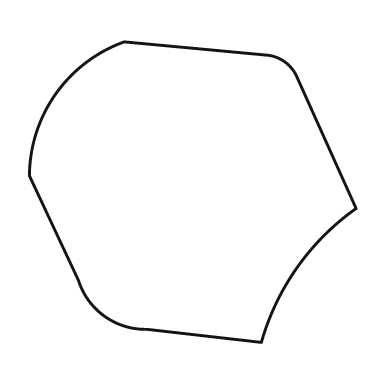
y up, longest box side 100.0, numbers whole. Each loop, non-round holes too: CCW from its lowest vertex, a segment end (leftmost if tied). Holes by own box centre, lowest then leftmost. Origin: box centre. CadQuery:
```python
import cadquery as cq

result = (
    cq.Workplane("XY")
    .moveTo(21.0, -46.0)
    .threePointArc((32.0, -23.0), (50.0, -5.0))
    .lineTo(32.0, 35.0)
    .threePointArc((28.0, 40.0), (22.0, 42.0))
    .lineTo(-21.0, 46.0)
    .threePointArc((-42.0, 30.0), (-50.0, 5.0))
    .lineTo(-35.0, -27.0)
    .threePointArc((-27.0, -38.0), (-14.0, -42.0))
    .close()
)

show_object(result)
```